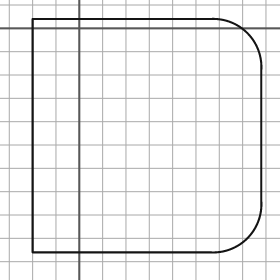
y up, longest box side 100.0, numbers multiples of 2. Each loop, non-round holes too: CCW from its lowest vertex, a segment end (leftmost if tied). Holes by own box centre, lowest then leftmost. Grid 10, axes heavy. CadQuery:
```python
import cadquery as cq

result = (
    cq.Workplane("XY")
    .moveTo(-20.0, -96.0)
    .lineTo(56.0, -96.0)
    .threePointArc((72.0, -90.0), (78.0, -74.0))
    .lineTo(78.0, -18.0)
    .threePointArc((72.0, -2.0), (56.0, 4.0))
    .lineTo(-20.0, 4.0)
    .close()
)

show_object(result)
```